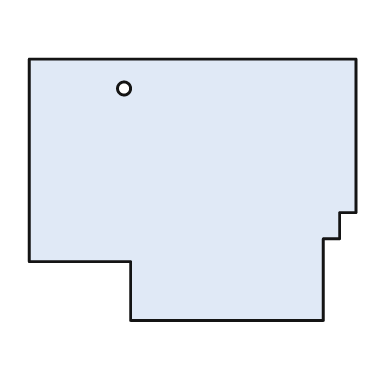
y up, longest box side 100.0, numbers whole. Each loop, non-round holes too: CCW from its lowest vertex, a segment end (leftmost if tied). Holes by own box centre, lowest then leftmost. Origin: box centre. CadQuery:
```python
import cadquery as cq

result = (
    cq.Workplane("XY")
    .moveTo(-19.0, -40.0)
    .lineTo(40.0, -40.0)
    .lineTo(40.0, -15.0)
    .lineTo(45.0, -15.0)
    .lineTo(45.0, -7.0)
    .lineTo(50.0, -7.0)
    .lineTo(50.0, 40.0)
    .lineTo(-50.0, 40.0)
    .lineTo(-50.0, -22.0)
    .lineTo(-19.0, -22.0)
    .close()
    .moveTo(-21.0, 31.0)
    .circle(2.0)
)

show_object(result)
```